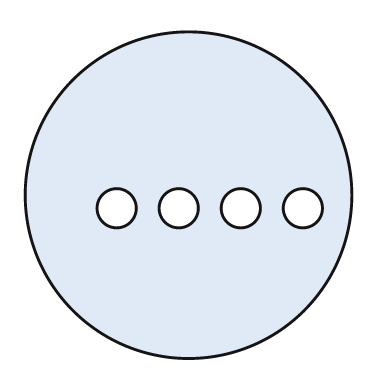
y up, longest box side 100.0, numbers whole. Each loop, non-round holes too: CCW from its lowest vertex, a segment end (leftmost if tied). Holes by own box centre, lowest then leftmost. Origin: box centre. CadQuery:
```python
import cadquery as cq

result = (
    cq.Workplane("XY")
    .moveTo(0.0, 0.0)
    .circle(50.0)
    .moveTo(-22.0, -4.0)
    .circle(6.0)
    .moveTo(-3.0, -4.0)
    .circle(6.0)
    .moveTo(16.0, -4.0)
    .circle(6.0)
    .moveTo(35.0, -4.0)
    .circle(6.0)
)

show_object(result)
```